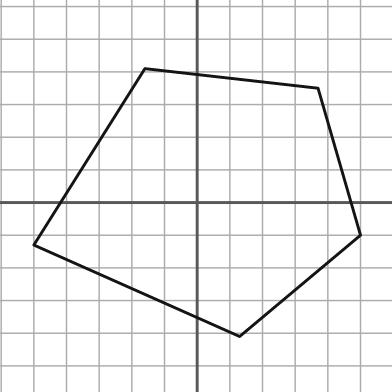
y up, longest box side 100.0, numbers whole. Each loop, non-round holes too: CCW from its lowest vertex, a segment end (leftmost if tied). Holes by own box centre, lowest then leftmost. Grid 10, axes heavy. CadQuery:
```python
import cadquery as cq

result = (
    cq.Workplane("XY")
    .moveTo(13.0, -41.0)
    .lineTo(50.0, -10.0)
    .lineTo(37.0, 35.0)
    .lineTo(-16.0, 41.0)
    .lineTo(-50.0, -13.0)
    .close()
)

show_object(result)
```